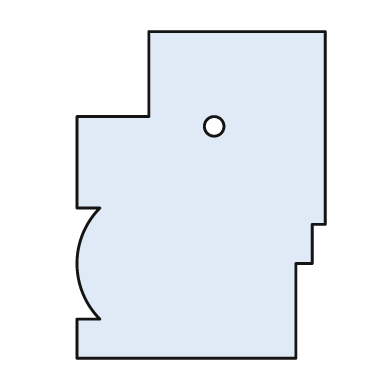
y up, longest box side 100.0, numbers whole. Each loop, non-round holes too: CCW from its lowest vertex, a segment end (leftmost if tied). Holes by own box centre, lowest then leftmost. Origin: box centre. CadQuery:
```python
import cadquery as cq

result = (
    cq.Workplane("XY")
    .moveTo(-38.0, -50.0)
    .lineTo(29.0, -50.0)
    .lineTo(29.0, -21.0)
    .lineTo(34.0, -21.0)
    .lineTo(34.0, -9.0)
    .lineTo(38.0, -9.0)
    .lineTo(38.0, 50.0)
    .lineTo(-16.0, 50.0)
    .lineTo(-16.0, 24.0)
    .lineTo(-38.0, 24.0)
    .lineTo(-38.0, -4.0)
    .lineTo(-31.0, -4.0)
    .threePointArc((-38.0, -21.0), (-31.0, -38.0))
    .lineTo(-38.0, -38.0)
    .close()
    .moveTo(4.0, 21.0)
    .circle(3.0)
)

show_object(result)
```